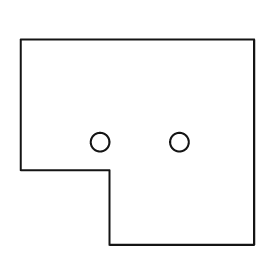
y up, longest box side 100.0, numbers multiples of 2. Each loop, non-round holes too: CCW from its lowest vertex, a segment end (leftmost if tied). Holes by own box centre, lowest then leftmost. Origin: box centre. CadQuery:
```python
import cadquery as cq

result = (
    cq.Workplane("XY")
    .moveTo(-12.0, -44.0)
    .lineTo(50.0, -44.0)
    .lineTo(50.0, 44.0)
    .lineTo(-50.0, 44.0)
    .lineTo(-50.0, -12.0)
    .lineTo(-12.0, -12.0)
    .close()
    .moveTo(-16.0, 0.0)
    .circle(4.0)
    .moveTo(18.0, 0.0)
    .circle(4.0)
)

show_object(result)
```